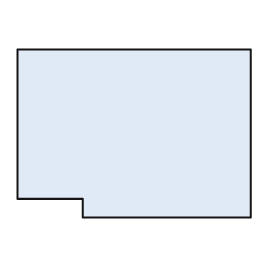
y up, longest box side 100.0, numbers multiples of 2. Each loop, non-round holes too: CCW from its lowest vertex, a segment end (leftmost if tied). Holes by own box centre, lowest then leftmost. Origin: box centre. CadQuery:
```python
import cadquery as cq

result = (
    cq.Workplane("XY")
    .moveTo(-22.0, -36.0)
    .lineTo(50.0, -36.0)
    .lineTo(50.0, 36.0)
    .lineTo(-50.0, 36.0)
    .lineTo(-50.0, -28.0)
    .lineTo(-22.0, -28.0)
    .close()
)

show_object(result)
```